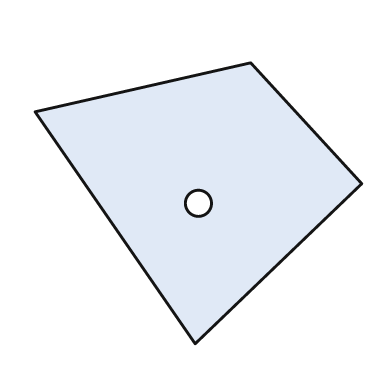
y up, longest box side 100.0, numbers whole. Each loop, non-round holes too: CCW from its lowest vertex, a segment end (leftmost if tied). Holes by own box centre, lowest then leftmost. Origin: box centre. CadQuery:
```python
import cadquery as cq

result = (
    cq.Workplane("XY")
    .moveTo(-1.0, -43.0)
    .lineTo(50.0, 6.0)
    .lineTo(16.0, 43.0)
    .lineTo(-50.0, 28.0)
    .close()
    .moveTo(0.0, 0.0)
    .circle(4.0)
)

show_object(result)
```